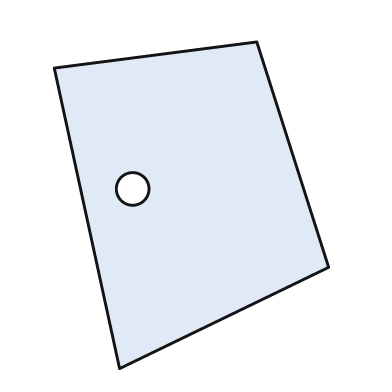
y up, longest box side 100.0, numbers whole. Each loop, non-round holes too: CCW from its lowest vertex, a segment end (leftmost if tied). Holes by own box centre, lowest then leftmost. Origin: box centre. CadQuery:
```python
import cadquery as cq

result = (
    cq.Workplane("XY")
    .moveTo(-22.0, -50.0)
    .lineTo(42.0, -19.0)
    .lineTo(20.0, 50.0)
    .lineTo(-42.0, 42.0)
    .close()
    .moveTo(-18.0, 5.0)
    .circle(5.0)
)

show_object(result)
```